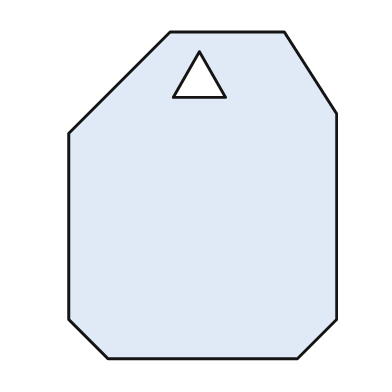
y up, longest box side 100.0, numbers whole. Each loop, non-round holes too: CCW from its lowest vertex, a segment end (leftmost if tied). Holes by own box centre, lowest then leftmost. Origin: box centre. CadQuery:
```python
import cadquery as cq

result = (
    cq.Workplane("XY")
    .moveTo(-29.0, -50.0)
    .lineTo(29.0, -50.0)
    .lineTo(41.0, -38.0)
    .lineTo(41.0, 25.0)
    .lineTo(25.0, 50.0)
    .lineTo(-10.0, 50.0)
    .lineTo(-41.0, 19.0)
    .lineTo(-41.0, -38.0)
    .close()
    .moveTo(-9.0, 30.0)
    .lineTo(7.0, 30.0)
    .lineTo(-1.0, 44.0)
    .close()
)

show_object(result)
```